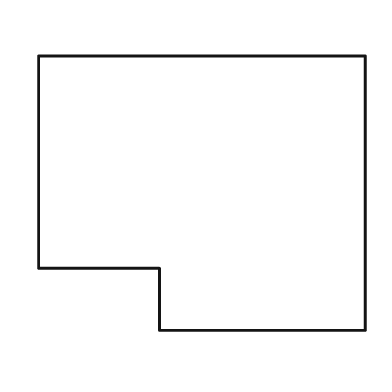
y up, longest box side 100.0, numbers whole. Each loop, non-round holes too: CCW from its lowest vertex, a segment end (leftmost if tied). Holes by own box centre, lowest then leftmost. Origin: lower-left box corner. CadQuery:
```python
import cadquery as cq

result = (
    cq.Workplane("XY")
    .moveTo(37.0, 0.0)
    .lineTo(100.0, 0.0)
    .lineTo(100.0, 84.0)
    .lineTo(0.0, 84.0)
    .lineTo(0.0, 19.0)
    .lineTo(37.0, 19.0)
    .close()
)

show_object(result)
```